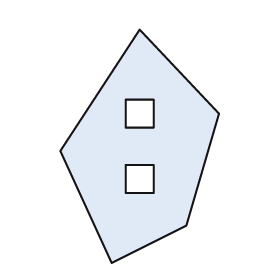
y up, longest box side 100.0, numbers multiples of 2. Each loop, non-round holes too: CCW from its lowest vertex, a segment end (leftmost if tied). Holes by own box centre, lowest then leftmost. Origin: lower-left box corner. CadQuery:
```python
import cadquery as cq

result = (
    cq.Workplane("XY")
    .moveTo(22.0, 0.0)
    .lineTo(54.0, 16.0)
    .lineTo(68.0, 64.0)
    .lineTo(34.0, 100.0)
    .lineTo(0.0, 48.0)
    .close()
    .moveTo(28.0, 30.0)
    .lineTo(40.0, 30.0)
    .lineTo(40.0, 42.0)
    .lineTo(28.0, 42.0)
    .close()
    .moveTo(28.0, 58.0)
    .lineTo(40.0, 58.0)
    .lineTo(40.0, 70.0)
    .lineTo(28.0, 70.0)
    .close()
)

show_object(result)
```